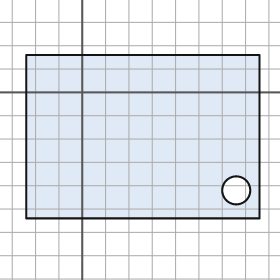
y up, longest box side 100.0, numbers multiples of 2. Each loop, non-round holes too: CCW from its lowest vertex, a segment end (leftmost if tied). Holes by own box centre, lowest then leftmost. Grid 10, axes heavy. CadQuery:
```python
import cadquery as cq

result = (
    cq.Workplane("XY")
    .moveTo(-24.0, -54.0)
    .lineTo(76.0, -54.0)
    .lineTo(76.0, 16.0)
    .lineTo(-24.0, 16.0)
    .close()
    .moveTo(66.0, -42.0)
    .circle(6.0)
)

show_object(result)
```